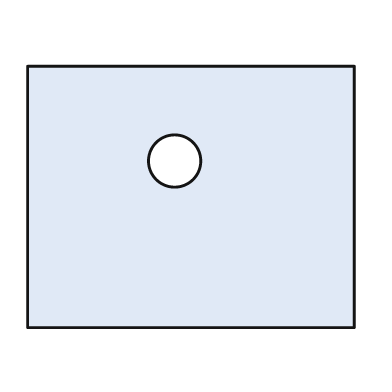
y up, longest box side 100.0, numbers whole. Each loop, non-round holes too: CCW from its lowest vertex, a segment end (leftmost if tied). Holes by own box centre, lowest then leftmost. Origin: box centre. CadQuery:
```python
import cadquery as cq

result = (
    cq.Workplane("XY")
    .moveTo(-50.0, -40.0)
    .lineTo(50.0, -40.0)
    .lineTo(50.0, 40.0)
    .lineTo(-50.0, 40.0)
    .close()
    .moveTo(-5.0, 11.0)
    .circle(8.0)
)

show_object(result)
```